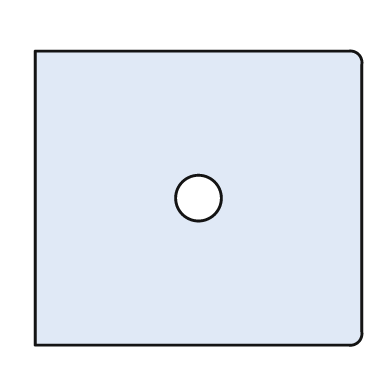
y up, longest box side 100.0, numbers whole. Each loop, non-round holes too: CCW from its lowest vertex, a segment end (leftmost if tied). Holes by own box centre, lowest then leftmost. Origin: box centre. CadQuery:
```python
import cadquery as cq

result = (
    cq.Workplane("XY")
    .moveTo(-50.0, -45.0)
    .lineTo(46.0, -45.0)
    .threePointArc((49.0, -44.0), (50.0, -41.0))
    .lineTo(50.0, 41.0)
    .threePointArc((49.0, 44.0), (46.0, 45.0))
    .lineTo(-50.0, 45.0)
    .close()
    .moveTo(0.0, 0.0)
    .circle(7.0)
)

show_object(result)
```